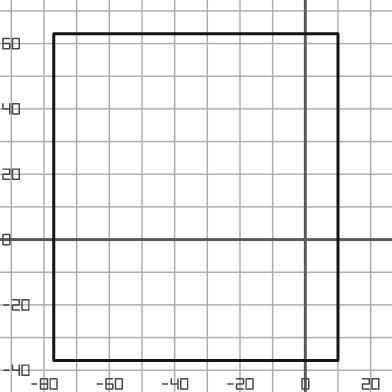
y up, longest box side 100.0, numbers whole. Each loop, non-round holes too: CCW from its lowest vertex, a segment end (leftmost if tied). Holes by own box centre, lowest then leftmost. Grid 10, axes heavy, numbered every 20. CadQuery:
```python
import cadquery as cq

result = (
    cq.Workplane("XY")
    .moveTo(-77.0, -37.0)
    .lineTo(10.0, -37.0)
    .lineTo(10.0, 63.0)
    .lineTo(-77.0, 63.0)
    .close()
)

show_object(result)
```